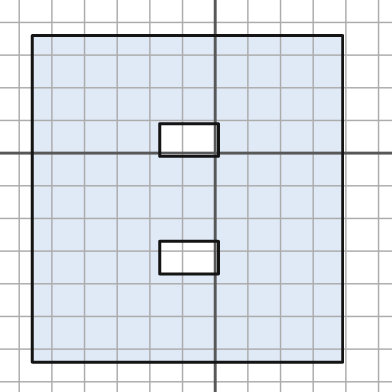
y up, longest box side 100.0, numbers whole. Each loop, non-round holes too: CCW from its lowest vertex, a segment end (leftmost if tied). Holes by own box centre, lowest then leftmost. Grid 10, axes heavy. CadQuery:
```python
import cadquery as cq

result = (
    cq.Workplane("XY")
    .moveTo(-56.0, -64.0)
    .lineTo(39.0, -64.0)
    .lineTo(39.0, 36.0)
    .lineTo(-56.0, 36.0)
    .close()
    .moveTo(-17.0, -37.0)
    .lineTo(1.0, -37.0)
    .lineTo(1.0, -27.0)
    .lineTo(-17.0, -27.0)
    .close()
    .moveTo(-17.0, -1.0)
    .lineTo(1.0, -1.0)
    .lineTo(1.0, 9.0)
    .lineTo(-17.0, 9.0)
    .close()
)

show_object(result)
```